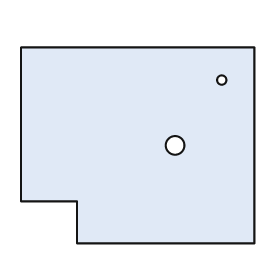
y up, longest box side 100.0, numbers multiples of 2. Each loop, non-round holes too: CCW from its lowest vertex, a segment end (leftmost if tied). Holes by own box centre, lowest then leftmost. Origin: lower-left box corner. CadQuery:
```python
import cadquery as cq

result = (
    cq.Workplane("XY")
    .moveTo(24.0, 0.0)
    .lineTo(100.0, 0.0)
    .lineTo(100.0, 84.0)
    .lineTo(0.0, 84.0)
    .lineTo(0.0, 18.0)
    .lineTo(24.0, 18.0)
    .close()
    .moveTo(66.0, 42.0)
    .circle(4.0)
    .moveTo(86.0, 70.0)
    .circle(2.0)
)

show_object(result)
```